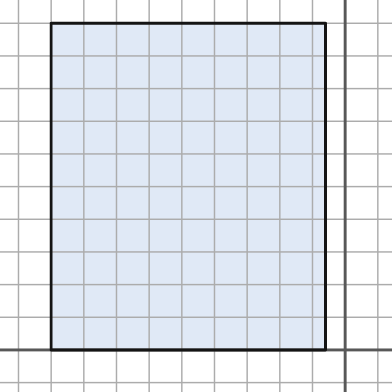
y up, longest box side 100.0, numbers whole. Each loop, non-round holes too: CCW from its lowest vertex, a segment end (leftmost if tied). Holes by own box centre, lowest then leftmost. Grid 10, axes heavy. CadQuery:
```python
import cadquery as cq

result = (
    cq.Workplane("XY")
    .moveTo(-90.0, 0.0)
    .lineTo(-6.0, 0.0)
    .lineTo(-6.0, 100.0)
    .lineTo(-90.0, 100.0)
    .close()
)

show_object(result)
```